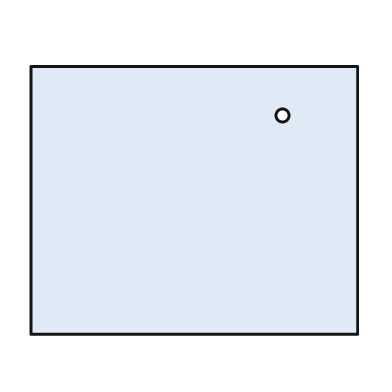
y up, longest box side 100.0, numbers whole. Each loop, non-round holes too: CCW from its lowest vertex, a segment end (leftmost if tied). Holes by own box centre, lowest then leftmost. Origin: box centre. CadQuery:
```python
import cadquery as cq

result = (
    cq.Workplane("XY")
    .moveTo(-50.0, -41.0)
    .lineTo(50.0, -41.0)
    .lineTo(50.0, 41.0)
    .lineTo(-50.0, 41.0)
    .close()
    .moveTo(27.0, 26.0)
    .circle(2.0)
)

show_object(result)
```